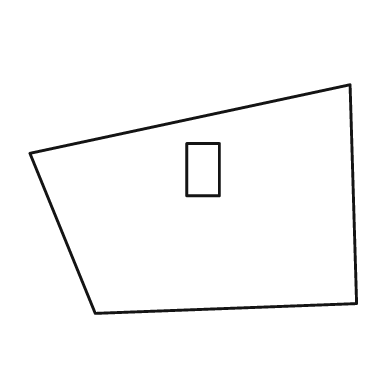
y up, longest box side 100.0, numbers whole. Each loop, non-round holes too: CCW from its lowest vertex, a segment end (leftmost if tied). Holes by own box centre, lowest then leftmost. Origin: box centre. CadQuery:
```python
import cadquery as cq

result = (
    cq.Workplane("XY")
    .moveTo(-30.0, -35.0)
    .lineTo(50.0, -32.0)
    .lineTo(48.0, 35.0)
    .lineTo(-50.0, 14.0)
    .close()
    .moveTo(-2.0, 1.0)
    .lineTo(8.0, 1.0)
    .lineTo(8.0, 17.0)
    .lineTo(-2.0, 17.0)
    .close()
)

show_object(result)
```